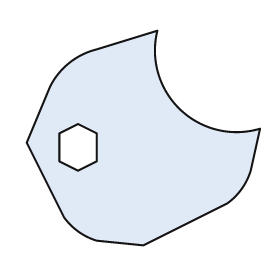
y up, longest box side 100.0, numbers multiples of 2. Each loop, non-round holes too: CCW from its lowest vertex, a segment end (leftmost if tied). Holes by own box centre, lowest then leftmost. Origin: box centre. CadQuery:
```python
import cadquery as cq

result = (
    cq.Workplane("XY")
    .moveTo(0.0, -46.0)
    .lineTo(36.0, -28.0)
    .threePointArc((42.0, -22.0), (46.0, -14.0))
    .lineTo(50.0, 4.0)
    .threePointArc((16.0, 12.0), (6.0, 46.0))
    .lineTo(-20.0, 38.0)
    .threePointArc((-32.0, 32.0), (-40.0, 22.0))
    .lineTo(-50.0, -2.0)
    .lineTo(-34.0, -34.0)
    .threePointArc((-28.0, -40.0), (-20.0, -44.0))
    .close()
    .moveTo(-28.0, -14.0)
    .lineTo(-20.0, -10.0)
    .lineTo(-20.0, 2.0)
    .lineTo(-28.0, 6.0)
    .lineTo(-36.0, 2.0)
    .lineTo(-36.0, -10.0)
    .close()
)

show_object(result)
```